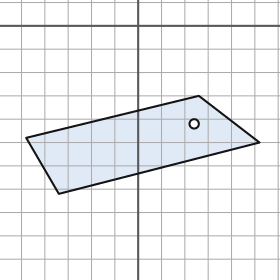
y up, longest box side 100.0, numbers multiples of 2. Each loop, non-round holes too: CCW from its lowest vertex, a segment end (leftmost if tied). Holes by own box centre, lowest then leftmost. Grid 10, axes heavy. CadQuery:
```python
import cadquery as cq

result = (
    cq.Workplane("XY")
    .moveTo(-34.0, -72.0)
    .lineTo(52.0, -50.0)
    .lineTo(26.0, -30.0)
    .lineTo(-48.0, -48.0)
    .close()
    .moveTo(24.0, -42.0)
    .circle(2.0)
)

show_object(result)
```